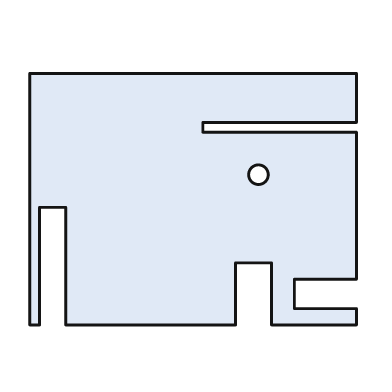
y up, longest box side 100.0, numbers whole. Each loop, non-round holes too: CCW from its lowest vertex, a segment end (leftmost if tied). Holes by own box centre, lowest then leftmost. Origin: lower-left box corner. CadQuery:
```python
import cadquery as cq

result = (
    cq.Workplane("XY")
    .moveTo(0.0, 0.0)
    .lineTo(3.0, 0.0)
    .lineTo(3.0, 36.0)
    .lineTo(11.0, 36.0)
    .lineTo(11.0, 0.0)
    .lineTo(63.0, 0.0)
    .lineTo(63.0, 19.0)
    .lineTo(74.0, 19.0)
    .lineTo(74.0, 0.0)
    .lineTo(100.0, 0.0)
    .lineTo(100.0, 5.0)
    .lineTo(81.0, 5.0)
    .lineTo(81.0, 14.0)
    .lineTo(100.0, 14.0)
    .lineTo(100.0, 59.0)
    .lineTo(53.0, 59.0)
    .lineTo(53.0, 62.0)
    .lineTo(100.0, 62.0)
    .lineTo(100.0, 77.0)
    .lineTo(0.0, 77.0)
    .close()
    .moveTo(70.0, 46.0)
    .circle(3.0)
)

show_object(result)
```